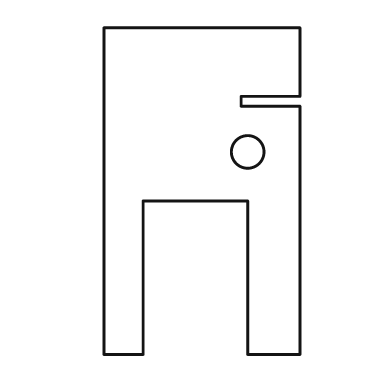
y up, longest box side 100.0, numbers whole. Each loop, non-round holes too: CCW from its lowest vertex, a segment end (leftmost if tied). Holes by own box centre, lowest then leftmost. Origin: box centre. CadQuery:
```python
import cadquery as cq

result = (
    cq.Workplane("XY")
    .moveTo(-30.0, -50.0)
    .lineTo(-18.0, -50.0)
    .lineTo(-18.0, -3.0)
    .lineTo(14.0, -3.0)
    .lineTo(14.0, -50.0)
    .lineTo(30.0, -50.0)
    .lineTo(30.0, 26.0)
    .lineTo(12.0, 26.0)
    .lineTo(12.0, 29.0)
    .lineTo(30.0, 29.0)
    .lineTo(30.0, 50.0)
    .lineTo(-30.0, 50.0)
    .close()
    .moveTo(14.0, 12.0)
    .circle(5.0)
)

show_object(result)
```